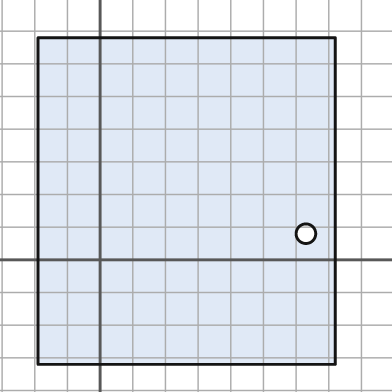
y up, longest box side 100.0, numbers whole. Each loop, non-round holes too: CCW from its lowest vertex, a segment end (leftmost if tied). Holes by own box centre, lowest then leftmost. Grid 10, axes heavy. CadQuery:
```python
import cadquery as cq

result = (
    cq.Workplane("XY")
    .moveTo(-19.0, -32.0)
    .lineTo(72.0, -32.0)
    .lineTo(72.0, 68.0)
    .lineTo(-19.0, 68.0)
    .close()
    .moveTo(63.0, 8.0)
    .circle(3.0)
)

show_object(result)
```